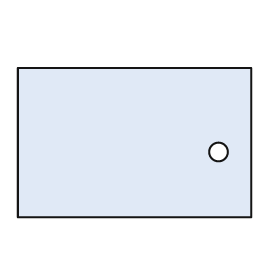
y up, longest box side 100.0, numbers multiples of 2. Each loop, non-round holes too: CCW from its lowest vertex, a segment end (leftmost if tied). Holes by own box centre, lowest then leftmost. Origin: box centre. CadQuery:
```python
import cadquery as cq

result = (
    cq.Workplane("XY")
    .moveTo(-50.0, -32.0)
    .lineTo(50.0, -32.0)
    .lineTo(50.0, 32.0)
    .lineTo(-50.0, 32.0)
    .close()
    .moveTo(36.0, -4.0)
    .circle(4.0)
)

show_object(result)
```